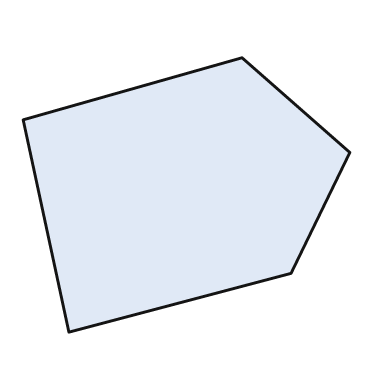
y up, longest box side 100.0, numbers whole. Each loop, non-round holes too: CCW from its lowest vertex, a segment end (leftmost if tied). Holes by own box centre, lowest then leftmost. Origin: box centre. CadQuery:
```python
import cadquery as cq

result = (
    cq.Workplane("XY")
    .moveTo(-36.0, -42.0)
    .lineTo(32.0, -24.0)
    .lineTo(50.0, 13.0)
    .lineTo(17.0, 42.0)
    .lineTo(-50.0, 23.0)
    .close()
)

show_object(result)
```